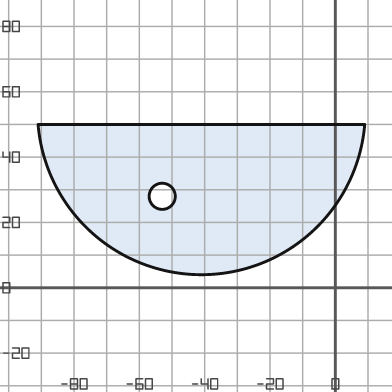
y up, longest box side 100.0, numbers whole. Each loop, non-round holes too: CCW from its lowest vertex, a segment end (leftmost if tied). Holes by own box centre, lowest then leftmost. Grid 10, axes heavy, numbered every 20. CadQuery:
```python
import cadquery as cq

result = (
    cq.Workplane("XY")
    .moveTo(-91.0, 50.0)
    .threePointArc((-41.0, 4.0), (9.0, 50.0))
    .close()
    .moveTo(-53.0, 28.0)
    .circle(4.0)
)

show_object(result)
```